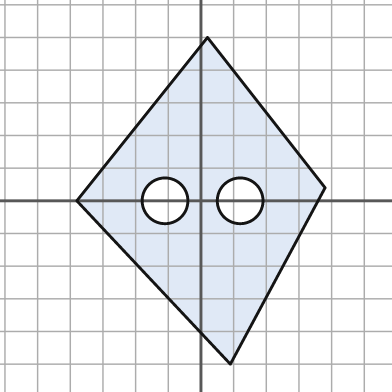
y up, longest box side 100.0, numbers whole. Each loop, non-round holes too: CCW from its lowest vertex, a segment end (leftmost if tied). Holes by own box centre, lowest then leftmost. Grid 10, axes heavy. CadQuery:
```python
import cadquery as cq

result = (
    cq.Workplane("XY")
    .moveTo(9.0, -50.0)
    .lineTo(38.0, 4.0)
    .lineTo(2.0, 50.0)
    .lineTo(-38.0, 0.0)
    .close()
    .moveTo(-11.0, 0.0)
    .circle(7.0)
    .moveTo(12.0, 0.0)
    .circle(7.0)
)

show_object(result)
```